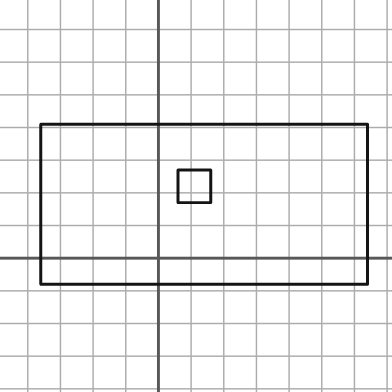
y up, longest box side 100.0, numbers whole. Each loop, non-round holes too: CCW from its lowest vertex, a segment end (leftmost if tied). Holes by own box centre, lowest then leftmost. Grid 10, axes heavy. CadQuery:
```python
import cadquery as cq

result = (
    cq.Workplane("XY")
    .moveTo(-36.0, -8.0)
    .lineTo(64.0, -8.0)
    .lineTo(64.0, 41.0)
    .lineTo(-36.0, 41.0)
    .close()
    .moveTo(6.0, 17.0)
    .lineTo(16.0, 17.0)
    .lineTo(16.0, 27.0)
    .lineTo(6.0, 27.0)
    .close()
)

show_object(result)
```